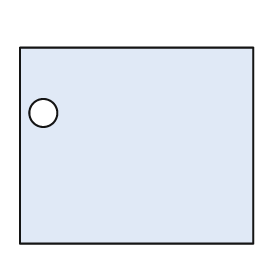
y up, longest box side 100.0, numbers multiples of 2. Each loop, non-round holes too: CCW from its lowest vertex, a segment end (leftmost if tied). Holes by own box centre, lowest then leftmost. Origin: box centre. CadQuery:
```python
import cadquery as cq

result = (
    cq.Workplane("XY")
    .moveTo(-50.0, -42.0)
    .lineTo(50.0, -42.0)
    .lineTo(50.0, 42.0)
    .lineTo(-50.0, 42.0)
    .close()
    .moveTo(-40.0, 14.0)
    .circle(6.0)
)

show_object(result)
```